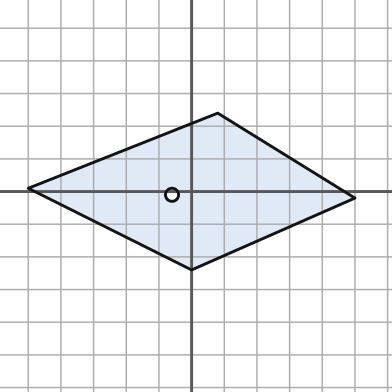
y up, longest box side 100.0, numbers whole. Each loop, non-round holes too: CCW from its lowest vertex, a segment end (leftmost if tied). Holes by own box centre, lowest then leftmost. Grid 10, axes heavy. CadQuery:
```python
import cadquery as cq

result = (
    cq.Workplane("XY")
    .moveTo(0.0, -24.0)
    .lineTo(50.0, -2.0)
    .lineTo(8.0, 24.0)
    .lineTo(-50.0, 1.0)
    .close()
    .moveTo(-6.0, -1.0)
    .circle(2.0)
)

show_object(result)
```